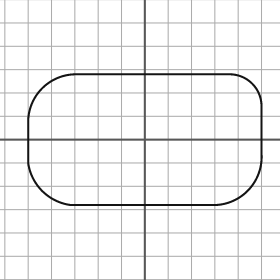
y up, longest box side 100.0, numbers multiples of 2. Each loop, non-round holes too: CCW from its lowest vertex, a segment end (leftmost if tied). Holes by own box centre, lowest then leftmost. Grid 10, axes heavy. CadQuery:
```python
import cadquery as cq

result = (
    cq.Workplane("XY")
    .moveTo(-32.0, -28.0)
    .lineTo(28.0, -28.0)
    .threePointArc((44.0, -22.0), (50.0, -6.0))
    .lineTo(50.0, 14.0)
    .threePointArc((46.0, 24.0), (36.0, 28.0))
    .lineTo(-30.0, 28.0)
    .threePointArc((-44.0, 22.0), (-50.0, 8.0))
    .lineTo(-50.0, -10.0)
    .threePointArc((-44.0, -22.0), (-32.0, -28.0))
    .close()
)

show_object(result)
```